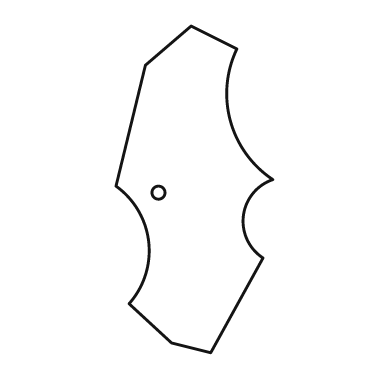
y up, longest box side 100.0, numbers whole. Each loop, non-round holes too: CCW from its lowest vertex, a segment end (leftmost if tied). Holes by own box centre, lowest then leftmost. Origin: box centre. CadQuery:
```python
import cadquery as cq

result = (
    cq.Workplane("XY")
    .moveTo(5.0, -50.0)
    .lineTo(21.0, -21.0)
    .threePointArc((15.0, -8.0), (24.0, 3.0))
    .threePointArc((11.0, 21.0), (13.0, 43.0))
    .lineTo(-1.0, 50.0)
    .lineTo(-15.0, 38.0)
    .lineTo(-24.0, 1.0)
    .threePointArc((-14.0, -16.0), (-20.0, -35.0))
    .lineTo(-7.0, -47.0)
    .close()
    .moveTo(-11.0, -1.0)
    .circle(2.0)
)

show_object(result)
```